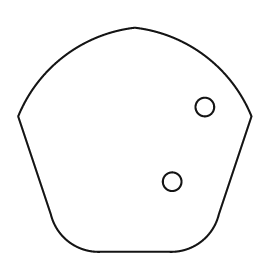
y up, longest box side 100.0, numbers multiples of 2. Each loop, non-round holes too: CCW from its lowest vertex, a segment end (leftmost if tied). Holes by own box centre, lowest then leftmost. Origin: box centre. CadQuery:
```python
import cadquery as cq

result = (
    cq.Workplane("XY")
    .moveTo(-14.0, -48.0)
    .lineTo(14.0, -48.0)
    .threePointArc((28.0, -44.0), (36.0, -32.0))
    .lineTo(50.0, 10.0)
    .threePointArc((30.0, 36.0), (0.0, 48.0))
    .threePointArc((-30.0, 36.0), (-50.0, 10.0))
    .lineTo(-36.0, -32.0)
    .threePointArc((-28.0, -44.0), (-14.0, -48.0))
    .close()
    .moveTo(16.0, -18.0)
    .circle(4.0)
    .moveTo(30.0, 14.0)
    .circle(4.0)
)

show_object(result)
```